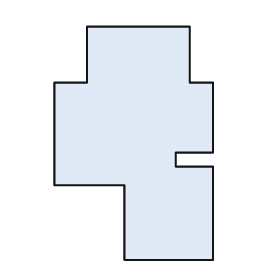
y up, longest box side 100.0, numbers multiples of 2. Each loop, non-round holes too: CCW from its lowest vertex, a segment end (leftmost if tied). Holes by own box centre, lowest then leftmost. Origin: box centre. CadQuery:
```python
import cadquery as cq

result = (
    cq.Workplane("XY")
    .moveTo(-4.0, -50.0)
    .lineTo(34.0, -50.0)
    .lineTo(34.0, -10.0)
    .lineTo(18.0, -10.0)
    .lineTo(18.0, -4.0)
    .lineTo(34.0, -4.0)
    .lineTo(34.0, 26.0)
    .lineTo(24.0, 26.0)
    .lineTo(24.0, 50.0)
    .lineTo(-20.0, 50.0)
    .lineTo(-20.0, 26.0)
    .lineTo(-34.0, 26.0)
    .lineTo(-34.0, -18.0)
    .lineTo(-4.0, -18.0)
    .close()
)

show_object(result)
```